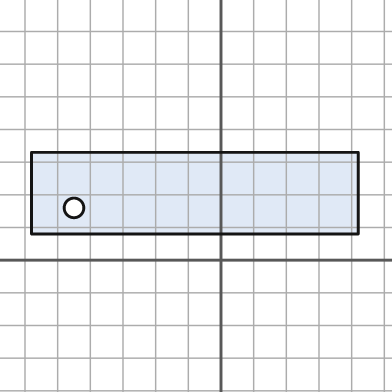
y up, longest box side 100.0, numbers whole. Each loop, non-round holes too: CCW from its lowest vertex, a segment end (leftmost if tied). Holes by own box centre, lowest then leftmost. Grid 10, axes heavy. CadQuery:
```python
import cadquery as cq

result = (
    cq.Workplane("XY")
    .moveTo(-58.0, 8.0)
    .lineTo(42.0, 8.0)
    .lineTo(42.0, 33.0)
    .lineTo(-58.0, 33.0)
    .close()
    .moveTo(-45.0, 16.0)
    .circle(3.0)
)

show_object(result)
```